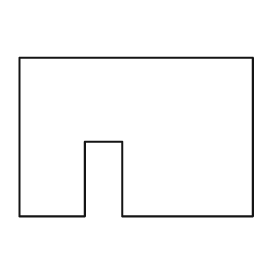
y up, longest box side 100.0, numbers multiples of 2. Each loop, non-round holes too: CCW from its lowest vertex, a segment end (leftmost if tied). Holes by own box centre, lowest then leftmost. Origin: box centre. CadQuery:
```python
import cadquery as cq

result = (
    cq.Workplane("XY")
    .moveTo(-50.0, -34.0)
    .lineTo(-22.0, -34.0)
    .lineTo(-22.0, -2.0)
    .lineTo(-6.0, -2.0)
    .lineTo(-6.0, -34.0)
    .lineTo(50.0, -34.0)
    .lineTo(50.0, 34.0)
    .lineTo(-50.0, 34.0)
    .close()
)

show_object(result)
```